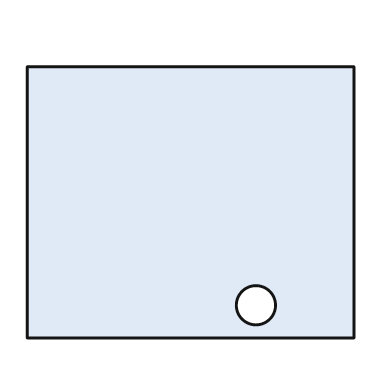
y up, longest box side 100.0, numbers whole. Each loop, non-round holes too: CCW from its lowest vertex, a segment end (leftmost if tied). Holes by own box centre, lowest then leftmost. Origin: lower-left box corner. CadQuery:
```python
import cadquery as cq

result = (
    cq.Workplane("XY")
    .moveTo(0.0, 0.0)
    .lineTo(100.0, 0.0)
    .lineTo(100.0, 83.0)
    .lineTo(0.0, 83.0)
    .close()
    .moveTo(70.0, 10.0)
    .circle(6.0)
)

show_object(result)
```